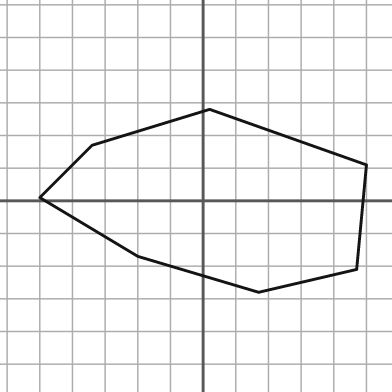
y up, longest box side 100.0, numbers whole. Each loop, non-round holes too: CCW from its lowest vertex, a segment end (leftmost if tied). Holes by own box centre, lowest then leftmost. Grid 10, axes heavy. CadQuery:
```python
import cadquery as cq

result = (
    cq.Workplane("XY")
    .moveTo(17.0, -28.0)
    .lineTo(47.0, -21.0)
    .lineTo(50.0, 11.0)
    .lineTo(2.0, 28.0)
    .lineTo(-34.0, 17.0)
    .lineTo(-50.0, 1.0)
    .lineTo(-20.0, -17.0)
    .close()
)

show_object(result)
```